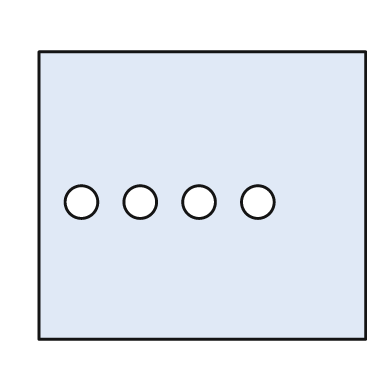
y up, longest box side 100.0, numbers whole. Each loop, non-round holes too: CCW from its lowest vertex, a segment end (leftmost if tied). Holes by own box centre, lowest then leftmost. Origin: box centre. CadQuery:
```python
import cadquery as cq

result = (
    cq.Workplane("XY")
    .moveTo(-50.0, -44.0)
    .lineTo(50.0, -44.0)
    .lineTo(50.0, 44.0)
    .lineTo(-50.0, 44.0)
    .close()
    .moveTo(-37.0, -2.0)
    .circle(5.0)
    .moveTo(-19.0, -2.0)
    .circle(5.0)
    .moveTo(-1.0, -2.0)
    .circle(5.0)
    .moveTo(17.0, -2.0)
    .circle(5.0)
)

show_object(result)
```